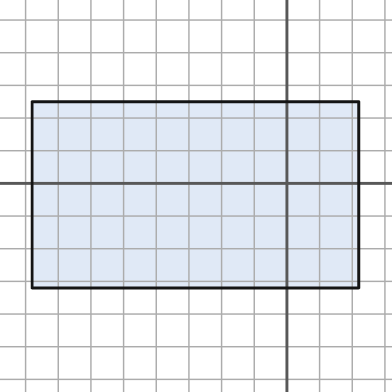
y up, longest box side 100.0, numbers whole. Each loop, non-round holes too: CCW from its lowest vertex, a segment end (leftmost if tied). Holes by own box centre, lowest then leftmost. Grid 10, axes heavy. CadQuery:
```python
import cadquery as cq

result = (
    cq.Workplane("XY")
    .moveTo(-78.0, -32.0)
    .lineTo(22.0, -32.0)
    .lineTo(22.0, 25.0)
    .lineTo(-78.0, 25.0)
    .close()
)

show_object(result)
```